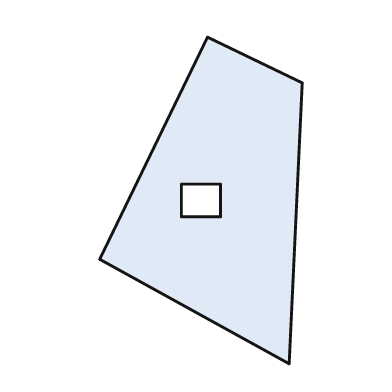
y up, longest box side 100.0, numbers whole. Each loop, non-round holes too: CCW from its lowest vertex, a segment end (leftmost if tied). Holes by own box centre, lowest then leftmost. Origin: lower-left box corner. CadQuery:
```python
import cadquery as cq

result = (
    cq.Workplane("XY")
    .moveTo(58.0, 0.0)
    .lineTo(62.0, 86.0)
    .lineTo(33.0, 100.0)
    .lineTo(0.0, 32.0)
    .close()
    .moveTo(25.0, 45.0)
    .lineTo(37.0, 45.0)
    .lineTo(37.0, 55.0)
    .lineTo(25.0, 55.0)
    .close()
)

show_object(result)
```